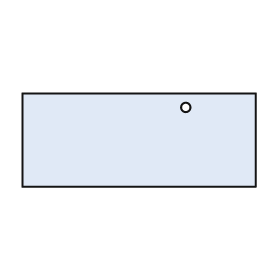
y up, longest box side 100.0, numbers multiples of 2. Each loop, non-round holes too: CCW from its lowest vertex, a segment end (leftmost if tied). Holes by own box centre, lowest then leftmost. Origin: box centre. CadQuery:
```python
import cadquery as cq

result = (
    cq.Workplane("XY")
    .moveTo(-50.0, -20.0)
    .lineTo(50.0, -20.0)
    .lineTo(50.0, 20.0)
    .lineTo(-50.0, 20.0)
    .close()
    .moveTo(20.0, 14.0)
    .circle(2.0)
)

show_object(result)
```